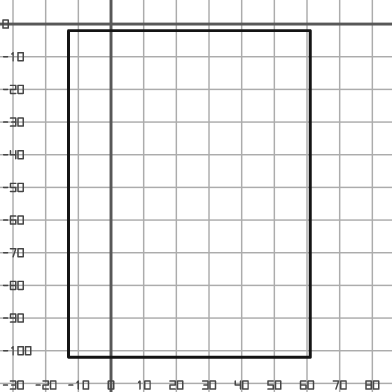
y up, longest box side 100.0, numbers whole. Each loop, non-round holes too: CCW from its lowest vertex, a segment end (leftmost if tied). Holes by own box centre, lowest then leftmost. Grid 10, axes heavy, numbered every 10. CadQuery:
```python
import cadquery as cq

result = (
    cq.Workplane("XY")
    .moveTo(-13.0, -102.0)
    .lineTo(61.0, -102.0)
    .lineTo(61.0, -2.0)
    .lineTo(-13.0, -2.0)
    .close()
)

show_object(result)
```